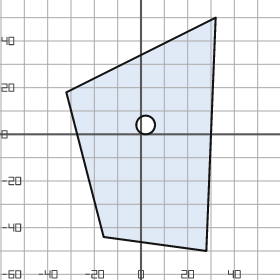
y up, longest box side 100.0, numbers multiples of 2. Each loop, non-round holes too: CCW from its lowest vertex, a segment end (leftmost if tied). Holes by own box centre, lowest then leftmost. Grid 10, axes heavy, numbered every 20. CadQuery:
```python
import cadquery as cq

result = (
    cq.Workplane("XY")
    .moveTo(28.0, -50.0)
    .lineTo(32.0, 50.0)
    .lineTo(-32.0, 18.0)
    .lineTo(-16.0, -44.0)
    .close()
    .moveTo(2.0, 4.0)
    .circle(4.0)
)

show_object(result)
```